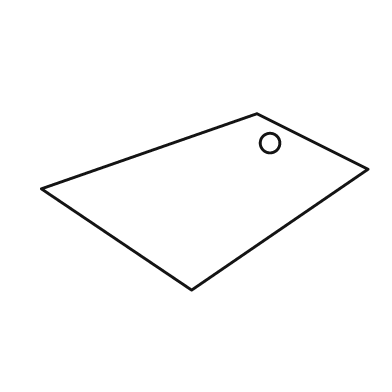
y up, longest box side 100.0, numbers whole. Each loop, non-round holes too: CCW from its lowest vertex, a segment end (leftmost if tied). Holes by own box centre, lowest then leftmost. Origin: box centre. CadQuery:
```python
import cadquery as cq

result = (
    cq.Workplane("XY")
    .moveTo(-4.0, -27.0)
    .lineTo(50.0, 10.0)
    .lineTo(16.0, 27.0)
    .lineTo(-50.0, 4.0)
    .close()
    .moveTo(20.0, 18.0)
    .circle(3.0)
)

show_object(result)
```